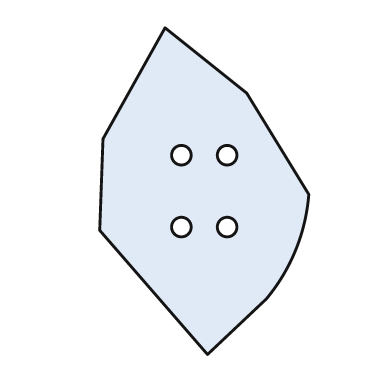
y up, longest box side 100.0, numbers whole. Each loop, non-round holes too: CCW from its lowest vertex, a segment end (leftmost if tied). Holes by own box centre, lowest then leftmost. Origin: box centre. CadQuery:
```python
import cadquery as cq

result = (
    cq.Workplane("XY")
    .moveTo(1.0, -50.0)
    .lineTo(19.0, -33.0)
    .threePointArc((28.0, -18.0), (32.0, -1.0))
    .lineTo(13.0, 30.0)
    .lineTo(-12.0, 50.0)
    .lineTo(-31.0, 16.0)
    .lineTo(-32.0, -12.0)
    .close()
    .moveTo(-7.0, -11.0)
    .circle(3.0)
    .moveTo(7.0, -11.0)
    .circle(3.0)
    .moveTo(-7.0, 11.0)
    .circle(3.0)
    .moveTo(7.0, 11.0)
    .circle(3.0)
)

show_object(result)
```